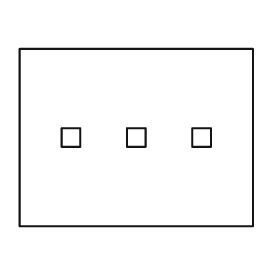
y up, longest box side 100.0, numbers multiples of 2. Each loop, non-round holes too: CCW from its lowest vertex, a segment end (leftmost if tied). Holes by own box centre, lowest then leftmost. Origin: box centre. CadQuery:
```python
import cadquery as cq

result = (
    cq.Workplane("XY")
    .moveTo(-50.0, -38.0)
    .lineTo(50.0, -38.0)
    .lineTo(50.0, 38.0)
    .lineTo(-50.0, 38.0)
    .close()
    .moveTo(-32.0, -4.0)
    .lineTo(-24.0, -4.0)
    .lineTo(-24.0, 4.0)
    .lineTo(-32.0, 4.0)
    .close()
    .moveTo(-4.0, -4.0)
    .lineTo(4.0, -4.0)
    .lineTo(4.0, 4.0)
    .lineTo(-4.0, 4.0)
    .close()
    .moveTo(24.0, -4.0)
    .lineTo(32.0, -4.0)
    .lineTo(32.0, 4.0)
    .lineTo(24.0, 4.0)
    .close()
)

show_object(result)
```